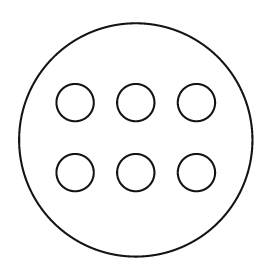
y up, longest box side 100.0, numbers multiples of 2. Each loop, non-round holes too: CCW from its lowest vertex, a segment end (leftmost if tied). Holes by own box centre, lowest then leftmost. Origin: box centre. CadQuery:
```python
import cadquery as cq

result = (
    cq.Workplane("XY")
    .moveTo(0.0, 0.0)
    .circle(50.0)
    .moveTo(-26.0, -14.0)
    .circle(8.0)
    .moveTo(0.0, -14.0)
    .circle(8.0)
    .moveTo(26.0, -14.0)
    .circle(8.0)
    .moveTo(-26.0, 16.0)
    .circle(8.0)
    .moveTo(0.0, 16.0)
    .circle(8.0)
    .moveTo(26.0, 16.0)
    .circle(8.0)
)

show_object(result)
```